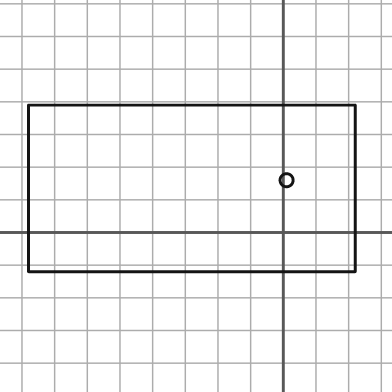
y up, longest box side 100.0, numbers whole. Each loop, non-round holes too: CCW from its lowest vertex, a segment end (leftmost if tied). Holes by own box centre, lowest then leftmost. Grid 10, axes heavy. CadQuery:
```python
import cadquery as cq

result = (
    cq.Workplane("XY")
    .moveTo(-78.0, -12.0)
    .lineTo(22.0, -12.0)
    .lineTo(22.0, 39.0)
    .lineTo(-78.0, 39.0)
    .close()
    .moveTo(1.0, 16.0)
    .circle(2.0)
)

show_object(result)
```